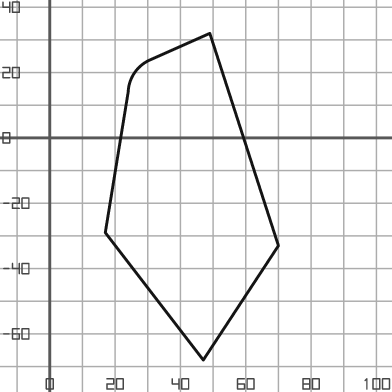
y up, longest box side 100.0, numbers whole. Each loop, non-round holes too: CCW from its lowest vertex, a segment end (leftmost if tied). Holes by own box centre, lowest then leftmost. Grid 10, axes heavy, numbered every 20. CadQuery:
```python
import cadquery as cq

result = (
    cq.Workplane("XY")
    .moveTo(47.0, -68.0)
    .lineTo(70.0, -33.0)
    .lineTo(49.0, 32.0)
    .lineTo(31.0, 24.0)
    .threePointArc((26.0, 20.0), (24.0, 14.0))
    .lineTo(17.0, -29.0)
    .close()
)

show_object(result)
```